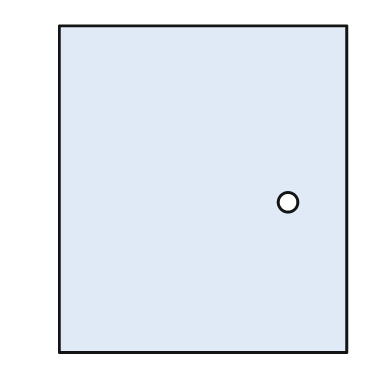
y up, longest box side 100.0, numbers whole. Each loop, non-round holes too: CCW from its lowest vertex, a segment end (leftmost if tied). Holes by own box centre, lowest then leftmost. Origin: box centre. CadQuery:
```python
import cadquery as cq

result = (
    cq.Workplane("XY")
    .moveTo(-44.0, -50.0)
    .lineTo(44.0, -50.0)
    .lineTo(44.0, 50.0)
    .lineTo(-44.0, 50.0)
    .close()
    .moveTo(26.0, -4.0)
    .circle(3.0)
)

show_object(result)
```